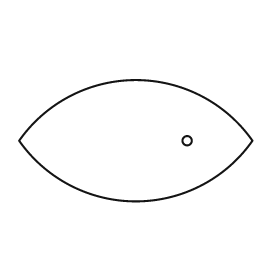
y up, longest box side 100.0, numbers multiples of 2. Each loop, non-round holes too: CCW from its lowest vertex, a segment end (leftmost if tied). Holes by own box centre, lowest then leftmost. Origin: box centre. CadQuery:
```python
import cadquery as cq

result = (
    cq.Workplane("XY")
    .moveTo(-50.0, 0.0)
    .threePointArc((0.0, -26.0), (50.0, 0.0))
    .threePointArc((0.0, 26.0), (-50.0, 0.0))
    .close()
    .moveTo(22.0, 0.0)
    .circle(2.0)
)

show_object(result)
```